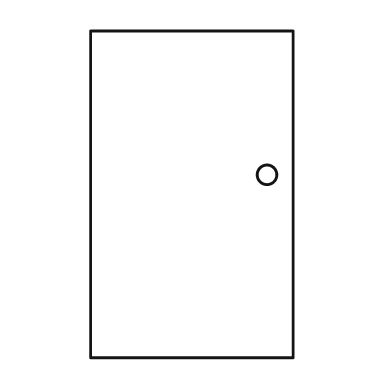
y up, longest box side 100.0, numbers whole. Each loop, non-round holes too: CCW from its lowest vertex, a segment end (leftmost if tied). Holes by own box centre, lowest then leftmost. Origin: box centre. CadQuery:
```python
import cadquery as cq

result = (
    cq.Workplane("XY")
    .moveTo(-31.0, -50.0)
    .lineTo(31.0, -50.0)
    .lineTo(31.0, 50.0)
    .lineTo(-31.0, 50.0)
    .close()
    .moveTo(23.0, 6.0)
    .circle(3.0)
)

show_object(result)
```